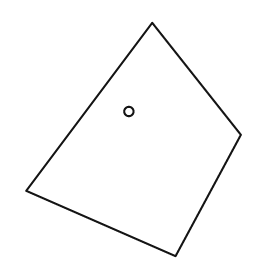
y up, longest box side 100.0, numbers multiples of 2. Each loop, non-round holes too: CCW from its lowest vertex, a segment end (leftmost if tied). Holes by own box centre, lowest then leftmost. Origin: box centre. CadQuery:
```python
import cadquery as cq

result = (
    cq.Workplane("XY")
    .moveTo(18.0, -50.0)
    .lineTo(46.0, 2.0)
    .lineTo(8.0, 50.0)
    .lineTo(-46.0, -22.0)
    .close()
    .moveTo(-2.0, 12.0)
    .circle(2.0)
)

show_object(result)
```